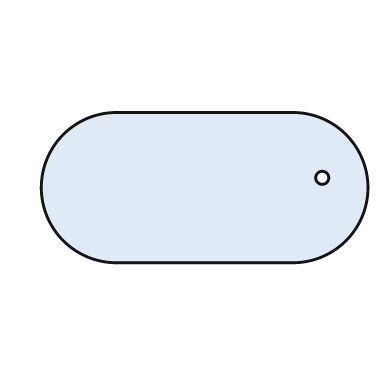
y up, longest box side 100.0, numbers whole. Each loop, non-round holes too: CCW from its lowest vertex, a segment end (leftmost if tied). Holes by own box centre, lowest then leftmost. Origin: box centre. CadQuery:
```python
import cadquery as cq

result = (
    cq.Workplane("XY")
    .moveTo(-27.0, -23.0)
    .lineTo(27.0, -23.0)
    .threePointArc((50.0, 0.0), (27.0, 23.0))
    .lineTo(-27.0, 23.0)
    .threePointArc((-50.0, 0.0), (-27.0, -23.0))
    .close()
    .moveTo(36.0, 3.0)
    .circle(2.0)
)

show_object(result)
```